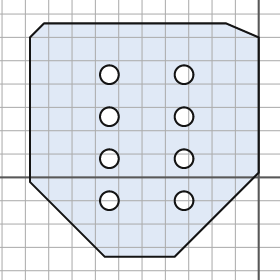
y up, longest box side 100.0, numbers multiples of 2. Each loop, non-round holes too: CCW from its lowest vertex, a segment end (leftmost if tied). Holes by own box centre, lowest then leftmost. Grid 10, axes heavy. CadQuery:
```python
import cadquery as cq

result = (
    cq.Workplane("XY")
    .moveTo(-66.0, -34.0)
    .lineTo(-36.0, -34.0)
    .lineTo(0.0, 2.0)
    .lineTo(0.0, 60.0)
    .lineTo(-14.0, 66.0)
    .lineTo(-92.0, 66.0)
    .lineTo(-98.0, 60.0)
    .lineTo(-98.0, -2.0)
    .close()
    .moveTo(-64.0, -10.0)
    .circle(4.0)
    .moveTo(-32.0, -10.0)
    .circle(4.0)
    .moveTo(-64.0, 8.0)
    .circle(4.0)
    .moveTo(-32.0, 8.0)
    .circle(4.0)
    .moveTo(-64.0, 26.0)
    .circle(4.0)
    .moveTo(-32.0, 26.0)
    .circle(4.0)
    .moveTo(-64.0, 44.0)
    .circle(4.0)
    .moveTo(-32.0, 44.0)
    .circle(4.0)
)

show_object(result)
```